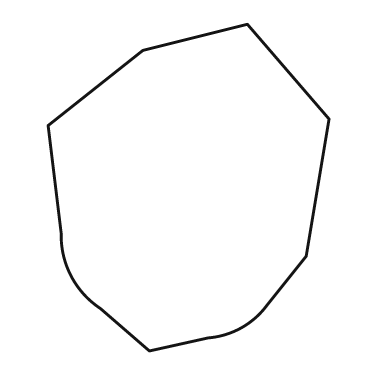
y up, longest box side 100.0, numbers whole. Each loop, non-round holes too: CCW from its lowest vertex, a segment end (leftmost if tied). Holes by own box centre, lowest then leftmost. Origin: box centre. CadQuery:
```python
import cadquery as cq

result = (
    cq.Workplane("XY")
    .moveTo(-12.0, -50.0)
    .lineTo(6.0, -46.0)
    .threePointArc((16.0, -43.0), (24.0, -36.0))
    .lineTo(36.0, -21.0)
    .lineTo(43.0, 21.0)
    .lineTo(18.0, 50.0)
    .lineTo(-14.0, 42.0)
    .lineTo(-43.0, 19.0)
    .lineTo(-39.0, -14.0)
    .threePointArc((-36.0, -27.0), (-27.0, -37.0))
    .close()
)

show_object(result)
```